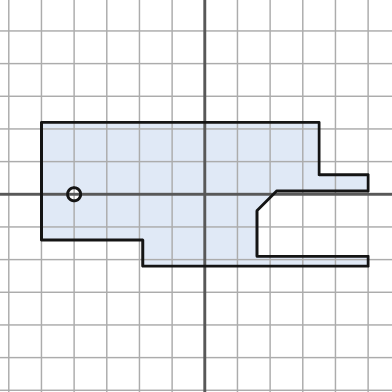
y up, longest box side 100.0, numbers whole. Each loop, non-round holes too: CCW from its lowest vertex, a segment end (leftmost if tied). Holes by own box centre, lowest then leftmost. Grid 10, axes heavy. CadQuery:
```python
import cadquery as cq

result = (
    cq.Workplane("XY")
    .moveTo(-19.0, -22.0)
    .lineTo(50.0, -22.0)
    .lineTo(50.0, -19.0)
    .lineTo(16.0, -19.0)
    .lineTo(16.0, -5.0)
    .lineTo(22.0, 1.0)
    .lineTo(50.0, 1.0)
    .lineTo(50.0, 6.0)
    .lineTo(35.0, 6.0)
    .lineTo(35.0, 22.0)
    .lineTo(-50.0, 22.0)
    .lineTo(-50.0, -14.0)
    .lineTo(-19.0, -14.0)
    .close()
    .moveTo(-40.0, 0.0)
    .circle(2.0)
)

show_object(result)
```